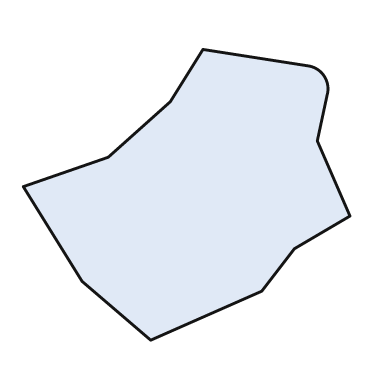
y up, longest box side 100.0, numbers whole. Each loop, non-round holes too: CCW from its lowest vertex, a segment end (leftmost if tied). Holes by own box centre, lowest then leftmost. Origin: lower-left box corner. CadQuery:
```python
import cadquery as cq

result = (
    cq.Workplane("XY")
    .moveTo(39.0, 0.0)
    .lineTo(73.0, 15.0)
    .lineTo(83.0, 28.0)
    .lineTo(100.0, 38.0)
    .lineTo(90.0, 61.0)
    .lineTo(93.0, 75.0)
    .threePointArc((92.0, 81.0), (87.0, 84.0))
    .lineTo(55.0, 89.0)
    .lineTo(45.0, 73.0)
    .lineTo(26.0, 56.0)
    .lineTo(0.0, 47.0)
    .lineTo(18.0, 18.0)
    .close()
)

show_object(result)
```